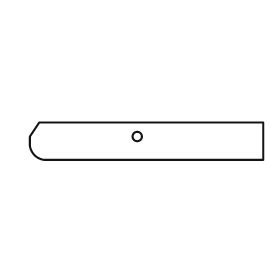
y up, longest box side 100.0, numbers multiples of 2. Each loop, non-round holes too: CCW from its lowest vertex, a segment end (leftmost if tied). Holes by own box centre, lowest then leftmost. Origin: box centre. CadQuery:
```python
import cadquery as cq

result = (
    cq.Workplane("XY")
    .moveTo(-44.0, -8.0)
    .lineTo(50.0, -8.0)
    .lineTo(50.0, 8.0)
    .lineTo(-46.0, 8.0)
    .lineTo(-50.0, 2.0)
    .lineTo(-50.0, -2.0)
    .threePointArc((-48.0, -6.0), (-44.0, -8.0))
    .close()
    .moveTo(-4.0, 2.0)
    .circle(2.0)
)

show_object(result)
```